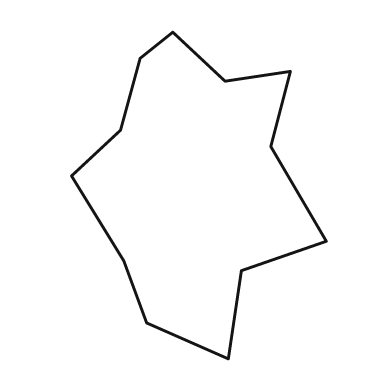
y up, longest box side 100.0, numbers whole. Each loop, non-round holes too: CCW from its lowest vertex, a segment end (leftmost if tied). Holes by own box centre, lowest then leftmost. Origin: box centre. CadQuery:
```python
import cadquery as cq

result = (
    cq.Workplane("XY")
    .moveTo(9.0, -50.0)
    .lineTo(13.0, -23.0)
    .lineTo(39.0, -14.0)
    .lineTo(22.0, 15.0)
    .lineTo(28.0, 38.0)
    .lineTo(8.0, 35.0)
    .lineTo(-8.0, 50.0)
    .lineTo(-18.0, 42.0)
    .lineTo(-24.0, 20.0)
    .lineTo(-39.0, 6.0)
    .lineTo(-23.0, -20.0)
    .lineTo(-16.0, -39.0)
    .close()
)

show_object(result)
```